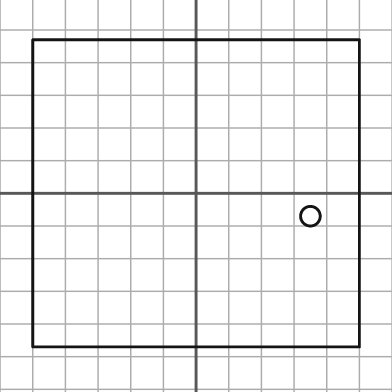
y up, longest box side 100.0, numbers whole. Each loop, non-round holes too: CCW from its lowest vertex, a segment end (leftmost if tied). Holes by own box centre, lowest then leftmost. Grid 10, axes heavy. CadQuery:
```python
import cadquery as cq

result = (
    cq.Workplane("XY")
    .moveTo(-50.0, -47.0)
    .lineTo(50.0, -47.0)
    .lineTo(50.0, 47.0)
    .lineTo(-50.0, 47.0)
    .close()
    .moveTo(35.0, -7.0)
    .circle(3.0)
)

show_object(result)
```